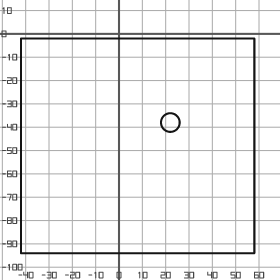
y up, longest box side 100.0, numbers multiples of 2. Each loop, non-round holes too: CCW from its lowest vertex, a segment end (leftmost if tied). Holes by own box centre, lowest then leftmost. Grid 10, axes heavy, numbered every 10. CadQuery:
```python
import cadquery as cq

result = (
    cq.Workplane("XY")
    .moveTo(-42.0, -94.0)
    .lineTo(58.0, -94.0)
    .lineTo(58.0, -2.0)
    .lineTo(-42.0, -2.0)
    .close()
    .moveTo(22.0, -38.0)
    .circle(4.0)
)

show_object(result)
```